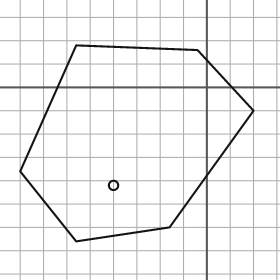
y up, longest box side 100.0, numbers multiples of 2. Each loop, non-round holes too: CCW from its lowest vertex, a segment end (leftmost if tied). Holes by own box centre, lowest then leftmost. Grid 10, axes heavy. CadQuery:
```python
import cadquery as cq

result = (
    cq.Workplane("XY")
    .moveTo(-56.0, -66.0)
    .lineTo(-16.0, -60.0)
    .lineTo(20.0, -10.0)
    .lineTo(-4.0, 16.0)
    .lineTo(-56.0, 18.0)
    .lineTo(-80.0, -36.0)
    .close()
    .moveTo(-40.0, -42.0)
    .circle(2.0)
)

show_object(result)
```